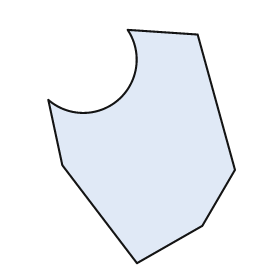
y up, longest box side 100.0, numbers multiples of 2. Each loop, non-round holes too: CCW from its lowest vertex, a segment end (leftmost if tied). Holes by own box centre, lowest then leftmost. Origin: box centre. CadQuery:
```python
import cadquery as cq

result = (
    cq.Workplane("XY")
    .moveTo(-2.0, -50.0)
    .lineTo(26.0, -34.0)
    .lineTo(40.0, -10.0)
    .lineTo(24.0, 48.0)
    .lineTo(-6.0, 50.0)
    .threePointArc((-10.0, 20.0), (-40.0, 20.0))
    .lineTo(-34.0, -8.0)
    .close()
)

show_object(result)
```